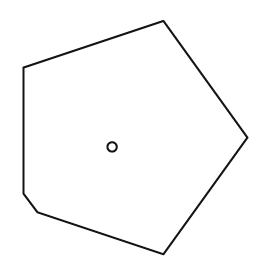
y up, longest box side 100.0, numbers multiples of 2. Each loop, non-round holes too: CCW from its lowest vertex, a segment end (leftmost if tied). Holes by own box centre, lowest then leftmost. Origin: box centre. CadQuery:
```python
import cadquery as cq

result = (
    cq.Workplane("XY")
    .moveTo(12.0, -50.0)
    .lineTo(48.0, 0.0)
    .lineTo(12.0, 50.0)
    .lineTo(-48.0, 30.0)
    .lineTo(-48.0, -24.0)
    .lineTo(-42.0, -32.0)
    .close()
    .moveTo(-10.0, -4.0)
    .circle(2.0)
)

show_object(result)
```